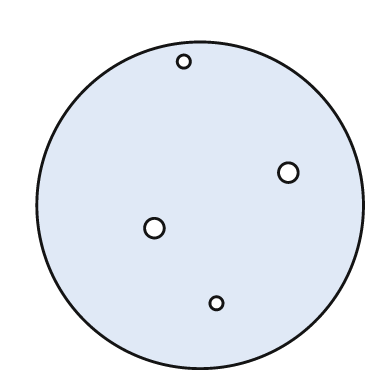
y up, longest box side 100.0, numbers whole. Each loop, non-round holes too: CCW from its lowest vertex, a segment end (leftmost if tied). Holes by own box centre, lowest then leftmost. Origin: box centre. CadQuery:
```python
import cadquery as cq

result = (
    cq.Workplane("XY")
    .moveTo(0.0, 0.0)
    .circle(50.0)
    .moveTo(5.0, -30.0)
    .circle(2.0)
    .moveTo(-14.0, -7.0)
    .circle(3.0)
    .moveTo(27.0, 10.0)
    .circle(3.0)
    .moveTo(-5.0, 44.0)
    .circle(2.0)
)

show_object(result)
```